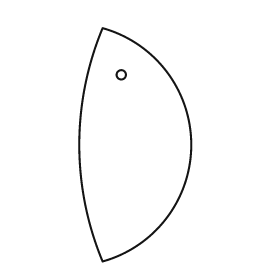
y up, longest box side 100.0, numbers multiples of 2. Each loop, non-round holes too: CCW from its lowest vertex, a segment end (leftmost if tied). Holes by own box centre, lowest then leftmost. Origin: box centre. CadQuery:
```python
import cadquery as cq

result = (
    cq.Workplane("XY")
    .moveTo(-14.0, -50.0)
    .threePointArc((24.0, 0.0), (-14.0, 50.0))
    .threePointArc((-24.0, 0.0), (-14.0, -50.0))
    .close()
    .moveTo(-6.0, 30.0)
    .circle(2.0)
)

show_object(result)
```